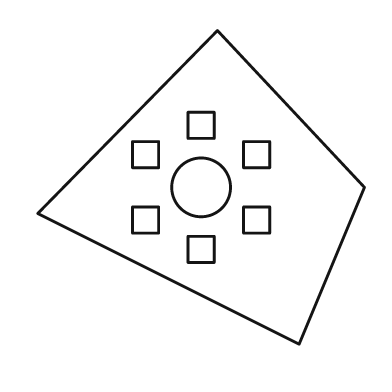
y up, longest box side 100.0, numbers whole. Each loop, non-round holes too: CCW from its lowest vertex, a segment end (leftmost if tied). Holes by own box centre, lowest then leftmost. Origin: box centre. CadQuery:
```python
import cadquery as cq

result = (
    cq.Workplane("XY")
    .moveTo(30.0, -48.0)
    .lineTo(50.0, 0.0)
    .lineTo(5.0, 48.0)
    .lineTo(-50.0, -8.0)
    .close()
    .moveTo(-4.0, -23.0)
    .lineTo(4.0, -23.0)
    .lineTo(4.0, -15.0)
    .lineTo(-4.0, -15.0)
    .close()
    .moveTo(-21.0, -14.0)
    .lineTo(-13.0, -14.0)
    .lineTo(-13.0, -6.0)
    .lineTo(-21.0, -6.0)
    .close()
    .moveTo(13.0, -14.0)
    .lineTo(21.0, -14.0)
    .lineTo(21.0, -6.0)
    .lineTo(13.0, -6.0)
    .close()
    .moveTo(0.0, 0.0)
    .circle(9.0)
    .moveTo(-21.0, 6.0)
    .lineTo(-13.0, 6.0)
    .lineTo(-13.0, 14.0)
    .lineTo(-21.0, 14.0)
    .close()
    .moveTo(13.0, 6.0)
    .lineTo(21.0, 6.0)
    .lineTo(21.0, 14.0)
    .lineTo(13.0, 14.0)
    .close()
    .moveTo(-4.0, 15.0)
    .lineTo(4.0, 15.0)
    .lineTo(4.0, 23.0)
    .lineTo(-4.0, 23.0)
    .close()
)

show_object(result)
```